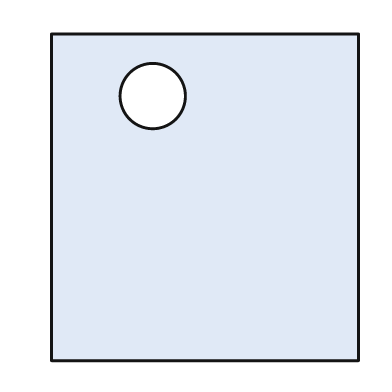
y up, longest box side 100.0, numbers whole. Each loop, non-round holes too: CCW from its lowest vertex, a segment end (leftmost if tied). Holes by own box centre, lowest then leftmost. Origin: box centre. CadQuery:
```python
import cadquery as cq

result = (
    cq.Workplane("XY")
    .moveTo(-47.0, -50.0)
    .lineTo(47.0, -50.0)
    .lineTo(47.0, 50.0)
    .lineTo(-47.0, 50.0)
    .close()
    .moveTo(-16.0, 31.0)
    .circle(10.0)
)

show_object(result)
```